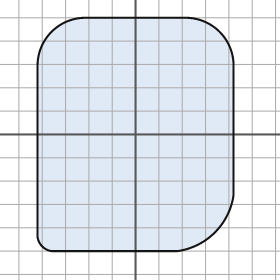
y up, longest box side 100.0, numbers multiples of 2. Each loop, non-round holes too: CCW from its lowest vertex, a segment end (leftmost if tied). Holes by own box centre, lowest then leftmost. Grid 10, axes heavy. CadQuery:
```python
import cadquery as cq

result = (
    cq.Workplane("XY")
    .moveTo(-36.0, -50.0)
    .lineTo(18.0, -50.0)
    .threePointArc((34.0, -42.0), (42.0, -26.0))
    .lineTo(42.0, 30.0)
    .threePointArc((36.0, 44.0), (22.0, 50.0))
    .lineTo(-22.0, 50.0)
    .threePointArc((-36.0, 44.0), (-42.0, 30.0))
    .lineTo(-42.0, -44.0)
    .threePointArc((-40.0, -48.0), (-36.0, -50.0))
    .close()
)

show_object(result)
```